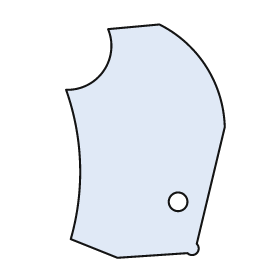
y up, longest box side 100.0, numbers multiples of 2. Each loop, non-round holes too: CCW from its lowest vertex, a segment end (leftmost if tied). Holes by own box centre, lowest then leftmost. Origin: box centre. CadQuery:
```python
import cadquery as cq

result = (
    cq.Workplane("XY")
    .moveTo(-12.0, -50.0)
    .lineTo(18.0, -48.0)
    .threePointArc((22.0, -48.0), (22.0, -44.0))
    .lineTo(34.0, 6.0)
    .threePointArc((26.0, 32.0), (6.0, 50.0))
    .lineTo(-16.0, 48.0)
    .threePointArc((-18.0, 30.0), (-34.0, 22.0))
    .threePointArc((-28.0, -10.0), (-32.0, -42.0))
    .close()
    .moveTo(14.0, -26.0)
    .circle(4.0)
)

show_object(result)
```